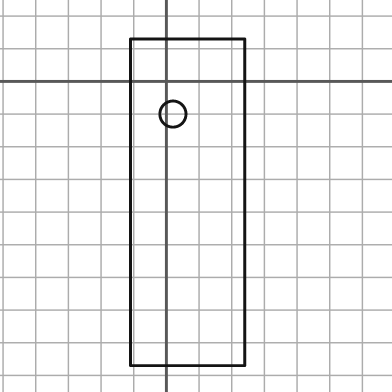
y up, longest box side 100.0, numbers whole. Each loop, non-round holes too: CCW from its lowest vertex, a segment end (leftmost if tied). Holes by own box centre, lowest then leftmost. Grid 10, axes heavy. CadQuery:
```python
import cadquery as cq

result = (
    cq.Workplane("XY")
    .moveTo(-11.0, -87.0)
    .lineTo(24.0, -87.0)
    .lineTo(24.0, 13.0)
    .lineTo(-11.0, 13.0)
    .close()
    .moveTo(2.0, -10.0)
    .circle(4.0)
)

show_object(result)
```